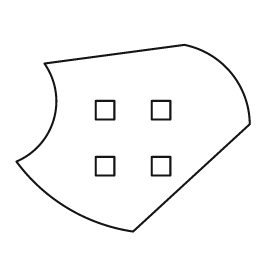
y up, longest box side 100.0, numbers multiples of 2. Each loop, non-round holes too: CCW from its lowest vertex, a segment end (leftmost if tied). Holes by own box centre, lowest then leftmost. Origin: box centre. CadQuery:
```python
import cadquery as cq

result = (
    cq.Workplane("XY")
    .moveTo(0.0, -40.0)
    .lineTo(50.0, 6.0)
    .threePointArc((42.0, 28.0), (22.0, 40.0))
    .lineTo(-38.0, 32.0)
    .threePointArc((-34.0, 8.0), (-50.0, -10.0))
    .threePointArc((-28.0, -30.0), (0.0, -40.0))
    .close()
    .moveTo(-16.0, -16.0)
    .lineTo(-8.0, -16.0)
    .lineTo(-8.0, -8.0)
    .lineTo(-16.0, -8.0)
    .close()
    .moveTo(8.0, -16.0)
    .lineTo(16.0, -16.0)
    .lineTo(16.0, -8.0)
    .lineTo(8.0, -8.0)
    .close()
    .moveTo(-16.0, 8.0)
    .lineTo(-8.0, 8.0)
    .lineTo(-8.0, 16.0)
    .lineTo(-16.0, 16.0)
    .close()
    .moveTo(8.0, 8.0)
    .lineTo(16.0, 8.0)
    .lineTo(16.0, 16.0)
    .lineTo(8.0, 16.0)
    .close()
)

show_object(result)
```